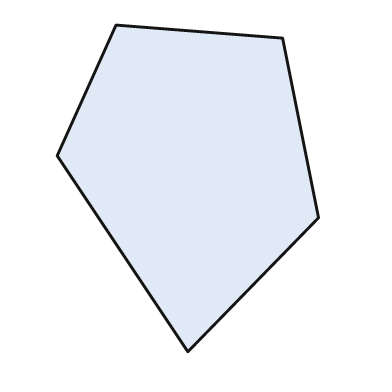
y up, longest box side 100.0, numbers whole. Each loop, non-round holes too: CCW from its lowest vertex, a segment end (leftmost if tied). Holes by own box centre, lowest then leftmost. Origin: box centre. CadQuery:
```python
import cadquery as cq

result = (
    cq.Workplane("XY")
    .moveTo(0.0, -50.0)
    .lineTo(40.0, -9.0)
    .lineTo(29.0, 46.0)
    .lineTo(-22.0, 50.0)
    .lineTo(-40.0, 10.0)
    .close()
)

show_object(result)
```